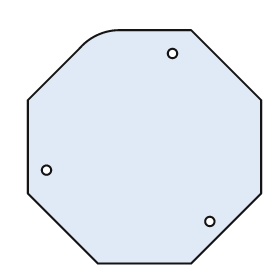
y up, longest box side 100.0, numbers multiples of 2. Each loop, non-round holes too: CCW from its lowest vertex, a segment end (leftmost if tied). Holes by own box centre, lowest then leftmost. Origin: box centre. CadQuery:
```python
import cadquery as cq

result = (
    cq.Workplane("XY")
    .moveTo(-20.0, -50.0)
    .lineTo(20.0, -50.0)
    .lineTo(50.0, -20.0)
    .lineTo(50.0, 20.0)
    .lineTo(20.0, 50.0)
    .lineTo(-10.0, 50.0)
    .threePointArc((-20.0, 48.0), (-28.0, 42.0))
    .lineTo(-50.0, 20.0)
    .lineTo(-50.0, -20.0)
    .close()
    .moveTo(28.0, -32.0)
    .circle(2.0)
    .moveTo(-42.0, -10.0)
    .circle(2.0)
    .moveTo(12.0, 40.0)
    .circle(2.0)
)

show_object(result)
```